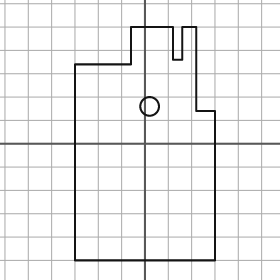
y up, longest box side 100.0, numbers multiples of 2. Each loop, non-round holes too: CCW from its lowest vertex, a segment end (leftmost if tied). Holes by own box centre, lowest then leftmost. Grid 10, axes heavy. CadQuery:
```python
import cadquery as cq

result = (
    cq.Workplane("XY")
    .moveTo(-30.0, -50.0)
    .lineTo(30.0, -50.0)
    .lineTo(30.0, 14.0)
    .lineTo(22.0, 14.0)
    .lineTo(22.0, 50.0)
    .lineTo(16.0, 50.0)
    .lineTo(16.0, 36.0)
    .lineTo(12.0, 36.0)
    .lineTo(12.0, 50.0)
    .lineTo(-6.0, 50.0)
    .lineTo(-6.0, 34.0)
    .lineTo(-30.0, 34.0)
    .close()
    .moveTo(2.0, 16.0)
    .circle(4.0)
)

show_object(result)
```